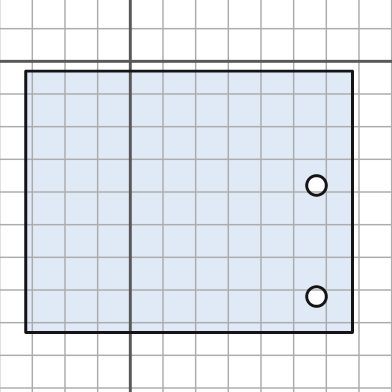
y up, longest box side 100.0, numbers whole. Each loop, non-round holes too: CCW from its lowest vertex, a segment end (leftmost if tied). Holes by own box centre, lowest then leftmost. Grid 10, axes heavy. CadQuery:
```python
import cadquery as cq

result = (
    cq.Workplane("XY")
    .moveTo(-32.0, -83.0)
    .lineTo(68.0, -83.0)
    .lineTo(68.0, -3.0)
    .lineTo(-32.0, -3.0)
    .close()
    .moveTo(57.0, -72.0)
    .circle(3.0)
    .moveTo(57.0, -38.0)
    .circle(3.0)
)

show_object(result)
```